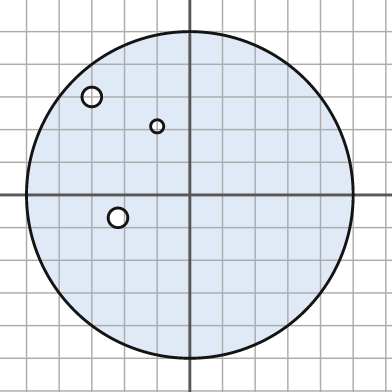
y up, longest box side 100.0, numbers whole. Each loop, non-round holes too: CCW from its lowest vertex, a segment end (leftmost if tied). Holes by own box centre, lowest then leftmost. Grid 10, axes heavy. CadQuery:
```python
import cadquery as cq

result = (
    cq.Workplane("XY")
    .moveTo(0.0, 0.0)
    .circle(50.0)
    .moveTo(-22.0, -7.0)
    .circle(3.0)
    .moveTo(-10.0, 21.0)
    .circle(2.0)
    .moveTo(-30.0, 30.0)
    .circle(3.0)
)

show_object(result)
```